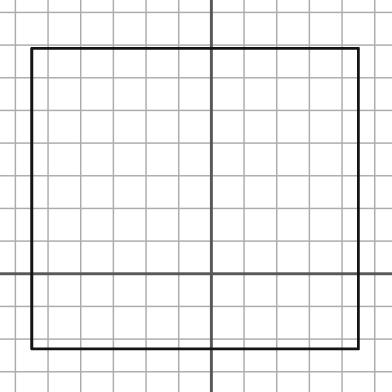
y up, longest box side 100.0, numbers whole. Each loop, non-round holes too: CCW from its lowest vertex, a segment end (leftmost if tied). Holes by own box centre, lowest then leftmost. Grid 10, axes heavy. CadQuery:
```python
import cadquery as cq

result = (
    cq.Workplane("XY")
    .moveTo(-55.0, -23.0)
    .lineTo(45.0, -23.0)
    .lineTo(45.0, 69.0)
    .lineTo(-55.0, 69.0)
    .close()
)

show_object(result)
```